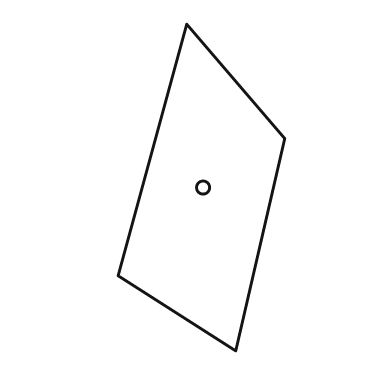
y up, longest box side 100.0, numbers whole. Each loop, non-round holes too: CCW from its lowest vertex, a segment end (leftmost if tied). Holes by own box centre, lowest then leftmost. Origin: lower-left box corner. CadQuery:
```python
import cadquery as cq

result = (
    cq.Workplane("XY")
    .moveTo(36.0, 0.0)
    .lineTo(51.0, 65.0)
    .lineTo(21.0, 100.0)
    .lineTo(0.0, 23.0)
    .close()
    .moveTo(26.0, 50.0)
    .circle(2.0)
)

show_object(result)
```